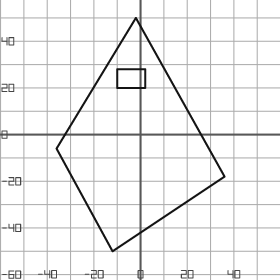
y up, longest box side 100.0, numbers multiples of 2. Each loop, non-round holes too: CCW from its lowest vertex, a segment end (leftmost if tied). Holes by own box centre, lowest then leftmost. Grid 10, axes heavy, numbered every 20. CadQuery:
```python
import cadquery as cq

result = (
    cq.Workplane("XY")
    .moveTo(-12.0, -50.0)
    .lineTo(36.0, -18.0)
    .lineTo(-2.0, 50.0)
    .lineTo(-36.0, -6.0)
    .close()
    .moveTo(-10.0, 20.0)
    .lineTo(2.0, 20.0)
    .lineTo(2.0, 28.0)
    .lineTo(-10.0, 28.0)
    .close()
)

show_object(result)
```